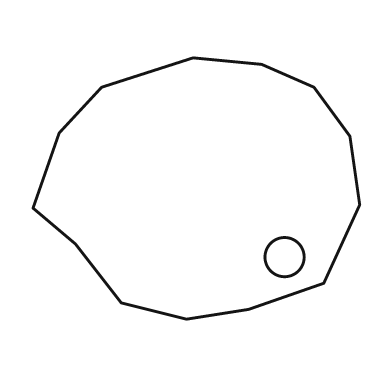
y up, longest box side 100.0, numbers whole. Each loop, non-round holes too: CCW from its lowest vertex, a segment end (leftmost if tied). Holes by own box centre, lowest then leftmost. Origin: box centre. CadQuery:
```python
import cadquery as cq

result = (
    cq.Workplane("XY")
    .moveTo(-3.0, -40.0)
    .lineTo(16.0, -37.0)
    .lineTo(39.0, -29.0)
    .lineTo(50.0, -5.0)
    .lineTo(47.0, 16.0)
    .lineTo(36.0, 31.0)
    .lineTo(20.0, 38.0)
    .lineTo(-1.0, 40.0)
    .lineTo(-29.0, 31.0)
    .lineTo(-42.0, 17.0)
    .lineTo(-50.0, -6.0)
    .lineTo(-37.0, -17.0)
    .lineTo(-23.0, -35.0)
    .close()
    .moveTo(27.0, -21.0)
    .circle(6.0)
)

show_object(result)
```